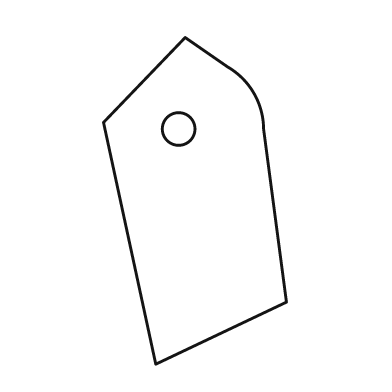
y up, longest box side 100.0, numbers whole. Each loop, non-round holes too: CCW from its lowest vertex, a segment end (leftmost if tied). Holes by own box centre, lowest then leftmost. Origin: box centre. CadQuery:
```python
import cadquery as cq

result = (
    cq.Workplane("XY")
    .moveTo(-12.0, -50.0)
    .lineTo(28.0, -31.0)
    .lineTo(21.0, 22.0)
    .threePointArc((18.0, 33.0), (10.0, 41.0))
    .lineTo(-3.0, 50.0)
    .lineTo(-28.0, 24.0)
    .close()
    .moveTo(-5.0, 22.0)
    .circle(5.0)
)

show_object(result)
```